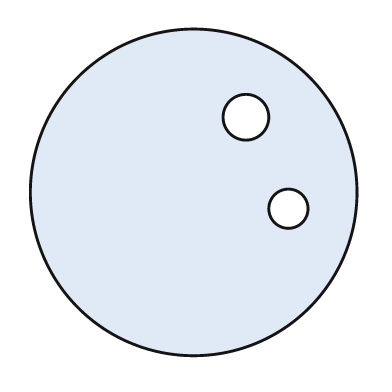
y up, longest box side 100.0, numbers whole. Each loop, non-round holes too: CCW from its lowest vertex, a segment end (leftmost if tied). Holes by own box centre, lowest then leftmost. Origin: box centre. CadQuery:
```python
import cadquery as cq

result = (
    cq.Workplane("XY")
    .moveTo(0.0, 0.0)
    .circle(50.0)
    .moveTo(29.0, -5.0)
    .circle(6.0)
    .moveTo(16.0, 23.0)
    .circle(7.0)
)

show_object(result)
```